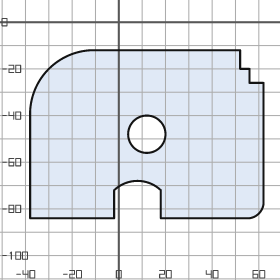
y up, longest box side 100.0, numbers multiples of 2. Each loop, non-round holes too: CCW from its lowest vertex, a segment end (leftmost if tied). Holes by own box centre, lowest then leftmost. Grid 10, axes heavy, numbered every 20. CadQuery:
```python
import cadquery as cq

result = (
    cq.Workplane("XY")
    .moveTo(-38.0, -84.0)
    .lineTo(-2.0, -84.0)
    .lineTo(-2.0, -72.0)
    .threePointArc((8.0, -68.0), (18.0, -72.0))
    .lineTo(18.0, -84.0)
    .lineTo(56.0, -84.0)
    .threePointArc((60.0, -82.0), (62.0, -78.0))
    .lineTo(62.0, -26.0)
    .lineTo(56.0, -26.0)
    .lineTo(56.0, -20.0)
    .lineTo(52.0, -20.0)
    .lineTo(52.0, -12.0)
    .lineTo(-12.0, -12.0)
    .threePointArc((-30.0, -20.0), (-38.0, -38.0))
    .close()
    .moveTo(12.0, -48.0)
    .circle(8.0)
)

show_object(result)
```